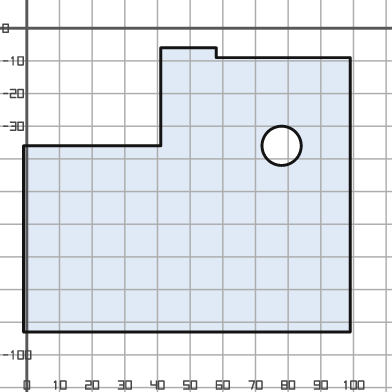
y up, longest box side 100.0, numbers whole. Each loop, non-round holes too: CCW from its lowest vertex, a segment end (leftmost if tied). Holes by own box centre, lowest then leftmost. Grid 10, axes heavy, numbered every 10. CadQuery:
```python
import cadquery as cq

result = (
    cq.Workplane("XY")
    .moveTo(-1.0, -93.0)
    .lineTo(99.0, -93.0)
    .lineTo(99.0, -9.0)
    .lineTo(58.0, -9.0)
    .lineTo(58.0, -6.0)
    .lineTo(41.0, -6.0)
    .lineTo(41.0, -36.0)
    .lineTo(-1.0, -36.0)
    .close()
    .moveTo(78.0, -36.0)
    .circle(6.0)
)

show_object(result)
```